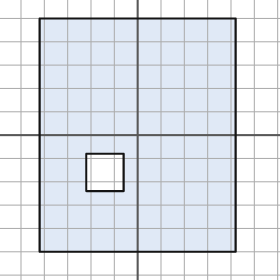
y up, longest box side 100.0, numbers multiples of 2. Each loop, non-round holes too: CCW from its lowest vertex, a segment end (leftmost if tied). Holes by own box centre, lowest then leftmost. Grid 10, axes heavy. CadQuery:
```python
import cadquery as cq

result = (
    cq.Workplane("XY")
    .moveTo(-42.0, -50.0)
    .lineTo(42.0, -50.0)
    .lineTo(42.0, 50.0)
    .lineTo(-42.0, 50.0)
    .close()
    .moveTo(-22.0, -24.0)
    .lineTo(-6.0, -24.0)
    .lineTo(-6.0, -8.0)
    .lineTo(-22.0, -8.0)
    .close()
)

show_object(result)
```